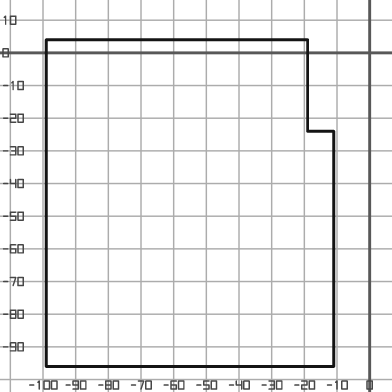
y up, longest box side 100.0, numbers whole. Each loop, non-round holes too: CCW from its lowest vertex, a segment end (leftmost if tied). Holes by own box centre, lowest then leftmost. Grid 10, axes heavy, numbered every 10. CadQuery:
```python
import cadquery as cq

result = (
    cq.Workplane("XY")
    .moveTo(-99.0, -96.0)
    .lineTo(-11.0, -96.0)
    .lineTo(-11.0, -24.0)
    .lineTo(-19.0, -24.0)
    .lineTo(-19.0, 4.0)
    .lineTo(-99.0, 4.0)
    .close()
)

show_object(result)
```